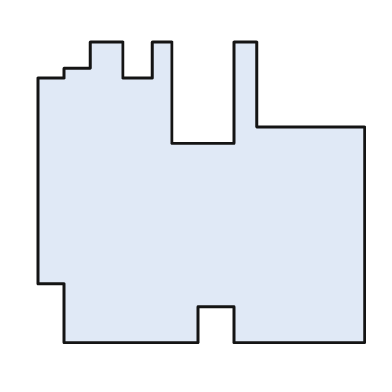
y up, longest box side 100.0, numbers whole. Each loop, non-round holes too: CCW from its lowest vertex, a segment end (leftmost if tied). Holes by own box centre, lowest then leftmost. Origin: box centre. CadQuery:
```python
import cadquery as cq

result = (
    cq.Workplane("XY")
    .moveTo(-42.0, -46.0)
    .lineTo(-1.0, -46.0)
    .lineTo(-1.0, -35.0)
    .lineTo(10.0, -35.0)
    .lineTo(10.0, -46.0)
    .lineTo(50.0, -46.0)
    .lineTo(50.0, 20.0)
    .lineTo(17.0, 20.0)
    .lineTo(17.0, 46.0)
    .lineTo(10.0, 46.0)
    .lineTo(10.0, 15.0)
    .lineTo(-9.0, 15.0)
    .lineTo(-9.0, 46.0)
    .lineTo(-15.0, 46.0)
    .lineTo(-15.0, 35.0)
    .lineTo(-24.0, 35.0)
    .lineTo(-24.0, 46.0)
    .lineTo(-34.0, 46.0)
    .lineTo(-34.0, 38.0)
    .lineTo(-42.0, 38.0)
    .lineTo(-42.0, 35.0)
    .lineTo(-50.0, 35.0)
    .lineTo(-50.0, -28.0)
    .lineTo(-42.0, -28.0)
    .close()
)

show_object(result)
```